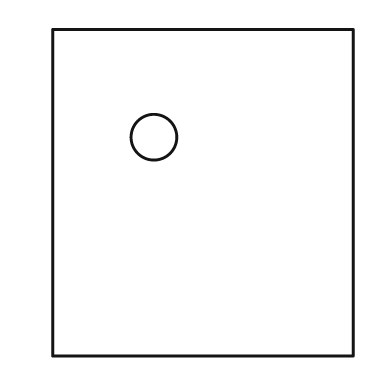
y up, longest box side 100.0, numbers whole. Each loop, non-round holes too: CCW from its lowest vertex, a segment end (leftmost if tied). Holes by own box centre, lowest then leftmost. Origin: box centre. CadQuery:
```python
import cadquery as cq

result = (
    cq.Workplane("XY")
    .moveTo(-46.0, -50.0)
    .lineTo(46.0, -50.0)
    .lineTo(46.0, 50.0)
    .lineTo(-46.0, 50.0)
    .close()
    .moveTo(-15.0, 17.0)
    .circle(7.0)
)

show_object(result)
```